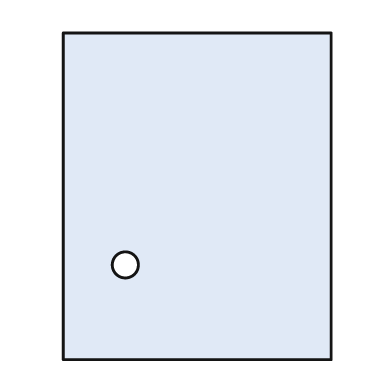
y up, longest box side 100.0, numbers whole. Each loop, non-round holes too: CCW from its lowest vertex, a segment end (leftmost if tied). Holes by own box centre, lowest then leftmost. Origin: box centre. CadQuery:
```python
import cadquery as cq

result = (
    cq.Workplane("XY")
    .moveTo(-41.0, -50.0)
    .lineTo(41.0, -50.0)
    .lineTo(41.0, 50.0)
    .lineTo(-41.0, 50.0)
    .close()
    .moveTo(-22.0, -21.0)
    .circle(4.0)
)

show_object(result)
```